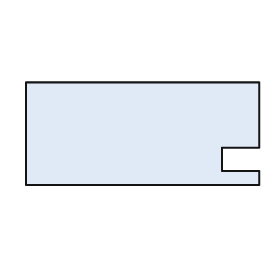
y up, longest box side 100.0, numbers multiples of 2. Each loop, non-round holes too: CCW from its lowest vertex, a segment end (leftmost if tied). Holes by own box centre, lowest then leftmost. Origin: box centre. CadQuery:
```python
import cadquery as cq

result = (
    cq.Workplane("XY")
    .moveTo(-50.0, -22.0)
    .lineTo(50.0, -22.0)
    .lineTo(50.0, -16.0)
    .lineTo(34.0, -16.0)
    .lineTo(34.0, -6.0)
    .lineTo(50.0, -6.0)
    .lineTo(50.0, 22.0)
    .lineTo(-50.0, 22.0)
    .close()
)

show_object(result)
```